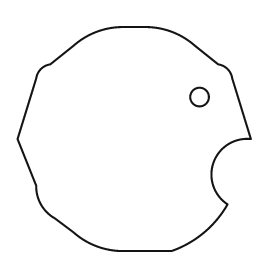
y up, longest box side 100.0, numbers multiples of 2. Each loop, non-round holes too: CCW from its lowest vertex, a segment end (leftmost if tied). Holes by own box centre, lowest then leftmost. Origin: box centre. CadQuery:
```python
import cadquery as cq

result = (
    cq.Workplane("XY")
    .moveTo(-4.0, -48.0)
    .lineTo(16.0, -48.0)
    .threePointArc((30.0, -40.0), (40.0, -28.0))
    .threePointArc((34.0, -10.0), (50.0, 0.0))
    .lineTo(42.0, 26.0)
    .threePointArc((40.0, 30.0), (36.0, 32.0))
    .lineTo(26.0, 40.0)
    .threePointArc((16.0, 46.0), (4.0, 48.0))
    .lineTo(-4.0, 48.0)
    .threePointArc((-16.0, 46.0), (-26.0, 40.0))
    .lineTo(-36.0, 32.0)
    .threePointArc((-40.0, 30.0), (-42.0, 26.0))
    .lineTo(-50.0, 0.0)
    .lineTo(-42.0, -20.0)
    .threePointArc((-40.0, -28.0), (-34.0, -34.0))
    .lineTo(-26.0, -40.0)
    .threePointArc((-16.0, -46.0), (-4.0, -48.0))
    .close()
    .moveTo(28.0, 18.0)
    .circle(4.0)
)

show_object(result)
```